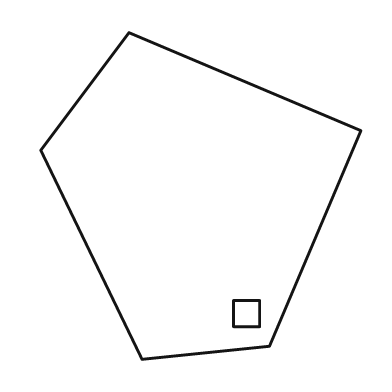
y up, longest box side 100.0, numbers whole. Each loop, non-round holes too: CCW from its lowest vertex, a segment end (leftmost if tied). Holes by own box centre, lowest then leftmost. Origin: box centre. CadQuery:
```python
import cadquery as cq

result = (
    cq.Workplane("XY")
    .moveTo(-18.0, -50.0)
    .lineTo(21.0, -46.0)
    .lineTo(49.0, 20.0)
    .lineTo(-22.0, 50.0)
    .lineTo(-49.0, 14.0)
    .close()
    .moveTo(10.0, -40.0)
    .lineTo(18.0, -40.0)
    .lineTo(18.0, -32.0)
    .lineTo(10.0, -32.0)
    .close()
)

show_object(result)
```